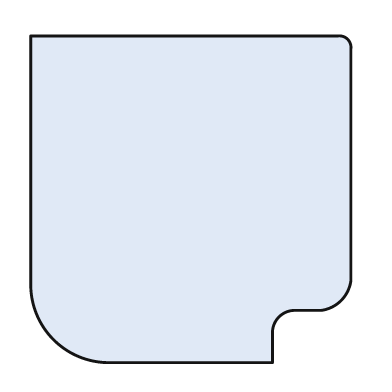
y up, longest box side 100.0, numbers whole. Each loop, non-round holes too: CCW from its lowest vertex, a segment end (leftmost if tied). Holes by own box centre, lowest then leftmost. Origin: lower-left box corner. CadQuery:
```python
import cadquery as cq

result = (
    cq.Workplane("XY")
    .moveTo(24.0, 0.0)
    .lineTo(74.0, 0.0)
    .lineTo(74.0, 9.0)
    .threePointArc((76.0, 14.0), (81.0, 16.0))
    .lineTo(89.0, 16.0)
    .threePointArc((95.0, 19.0), (98.0, 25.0))
    .lineTo(98.0, 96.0)
    .threePointArc((97.0, 99.0), (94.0, 100.0))
    .lineTo(0.0, 100.0)
    .lineTo(0.0, 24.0)
    .threePointArc((7.0, 7.0), (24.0, 0.0))
    .close()
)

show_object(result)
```